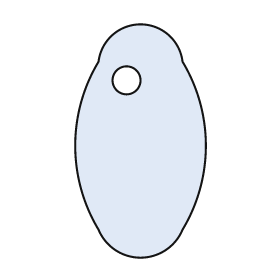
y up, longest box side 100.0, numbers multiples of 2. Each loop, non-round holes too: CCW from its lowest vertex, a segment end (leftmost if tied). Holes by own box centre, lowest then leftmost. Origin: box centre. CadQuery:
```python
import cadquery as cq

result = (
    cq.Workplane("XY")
    .moveTo(-18.0, -38.0)
    .threePointArc((0.0, -50.0), (18.0, -38.0))
    .threePointArc((28.0, -2.0), (18.0, 34.0))
    .threePointArc((0.0, 50.0), (-18.0, 34.0))
    .threePointArc((-28.0, -2.0), (-18.0, -38.0))
    .close()
    .moveTo(-6.0, 26.0)
    .circle(6.0)
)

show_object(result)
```